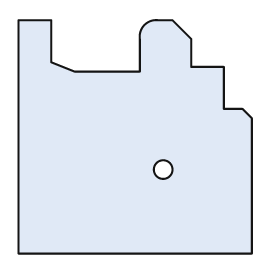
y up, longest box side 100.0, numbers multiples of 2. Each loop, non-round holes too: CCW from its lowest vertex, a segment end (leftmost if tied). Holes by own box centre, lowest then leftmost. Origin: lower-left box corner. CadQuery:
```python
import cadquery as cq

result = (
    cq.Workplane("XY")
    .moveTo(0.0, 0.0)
    .lineTo(100.0, 0.0)
    .lineTo(100.0, 58.0)
    .lineTo(96.0, 62.0)
    .lineTo(88.0, 62.0)
    .lineTo(88.0, 80.0)
    .lineTo(74.0, 80.0)
    .lineTo(74.0, 92.0)
    .lineTo(66.0, 100.0)
    .lineTo(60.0, 100.0)
    .threePointArc((54.0, 98.0), (52.0, 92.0))
    .lineTo(52.0, 78.0)
    .lineTo(24.0, 78.0)
    .lineTo(14.0, 82.0)
    .lineTo(14.0, 100.0)
    .lineTo(0.0, 100.0)
    .close()
    .moveTo(62.0, 36.0)
    .circle(4.0)
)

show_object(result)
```